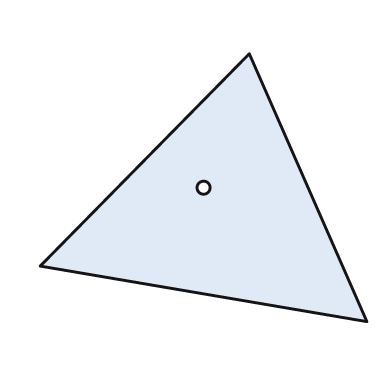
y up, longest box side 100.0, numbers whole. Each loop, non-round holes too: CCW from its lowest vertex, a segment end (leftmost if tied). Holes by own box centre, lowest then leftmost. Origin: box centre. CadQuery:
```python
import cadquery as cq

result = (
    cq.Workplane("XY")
    .moveTo(50.0, -41.0)
    .lineTo(14.0, 41.0)
    .lineTo(-50.0, -24.0)
    .close()
    .moveTo(0.0, 0.0)
    .circle(2.0)
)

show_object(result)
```